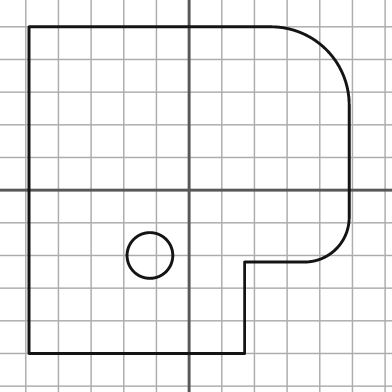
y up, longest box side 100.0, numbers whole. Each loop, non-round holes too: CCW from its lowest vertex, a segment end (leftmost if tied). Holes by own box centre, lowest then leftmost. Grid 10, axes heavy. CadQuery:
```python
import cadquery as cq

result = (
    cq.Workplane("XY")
    .moveTo(-49.0, -50.0)
    .lineTo(17.0, -50.0)
    .lineTo(17.0, -22.0)
    .lineTo(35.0, -22.0)
    .threePointArc((45.0, -18.0), (49.0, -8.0))
    .lineTo(49.0, 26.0)
    .threePointArc((42.0, 43.0), (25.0, 50.0))
    .lineTo(-49.0, 50.0)
    .close()
    .moveTo(-12.0, -20.0)
    .circle(7.0)
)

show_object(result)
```